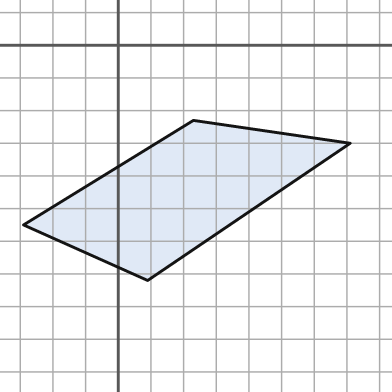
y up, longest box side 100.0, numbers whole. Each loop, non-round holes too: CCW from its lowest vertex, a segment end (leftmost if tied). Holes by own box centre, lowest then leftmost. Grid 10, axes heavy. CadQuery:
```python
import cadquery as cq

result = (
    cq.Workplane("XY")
    .moveTo(9.0, -72.0)
    .lineTo(71.0, -30.0)
    .lineTo(23.0, -23.0)
    .lineTo(-29.0, -55.0)
    .close()
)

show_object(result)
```